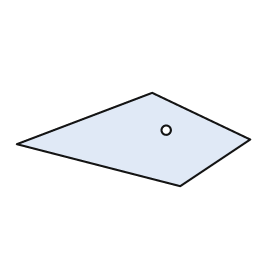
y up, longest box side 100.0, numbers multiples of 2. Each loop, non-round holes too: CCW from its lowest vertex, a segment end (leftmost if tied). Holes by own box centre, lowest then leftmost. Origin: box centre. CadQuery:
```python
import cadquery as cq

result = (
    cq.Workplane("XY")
    .moveTo(20.0, -20.0)
    .lineTo(50.0, 0.0)
    .lineTo(8.0, 20.0)
    .lineTo(-50.0, -2.0)
    .close()
    .moveTo(14.0, 4.0)
    .circle(2.0)
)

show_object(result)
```